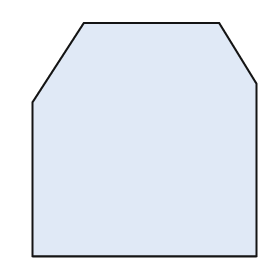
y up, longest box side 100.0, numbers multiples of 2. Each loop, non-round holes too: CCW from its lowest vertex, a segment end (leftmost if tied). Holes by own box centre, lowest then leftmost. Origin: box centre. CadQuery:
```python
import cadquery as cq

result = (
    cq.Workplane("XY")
    .moveTo(-48.0, -50.0)
    .lineTo(48.0, -50.0)
    .lineTo(48.0, 24.0)
    .lineTo(32.0, 50.0)
    .lineTo(-26.0, 50.0)
    .lineTo(-48.0, 16.0)
    .close()
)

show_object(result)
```